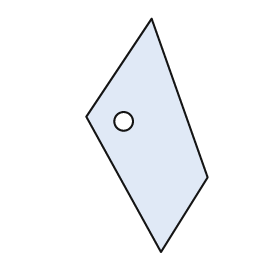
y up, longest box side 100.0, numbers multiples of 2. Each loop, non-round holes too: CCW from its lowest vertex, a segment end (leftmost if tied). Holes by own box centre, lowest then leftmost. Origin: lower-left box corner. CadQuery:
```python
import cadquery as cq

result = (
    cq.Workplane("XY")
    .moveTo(32.0, 0.0)
    .lineTo(52.0, 32.0)
    .lineTo(28.0, 100.0)
    .lineTo(0.0, 58.0)
    .close()
    .moveTo(16.0, 56.0)
    .circle(4.0)
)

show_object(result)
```